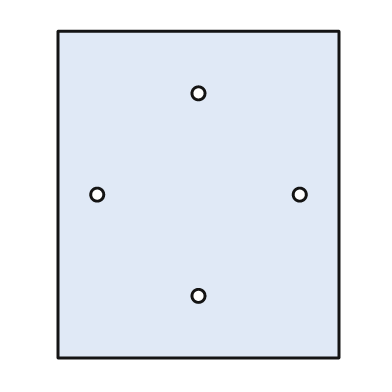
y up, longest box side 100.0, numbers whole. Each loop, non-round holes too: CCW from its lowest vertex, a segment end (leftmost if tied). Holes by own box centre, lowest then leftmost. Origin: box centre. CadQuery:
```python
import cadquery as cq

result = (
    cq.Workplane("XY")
    .moveTo(-43.0, -50.0)
    .lineTo(43.0, -50.0)
    .lineTo(43.0, 50.0)
    .lineTo(-43.0, 50.0)
    .close()
    .moveTo(0.0, -31.0)
    .circle(2.0)
    .moveTo(-31.0, 0.0)
    .circle(2.0)
    .moveTo(31.0, 0.0)
    .circle(2.0)
    .moveTo(0.0, 31.0)
    .circle(2.0)
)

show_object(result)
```